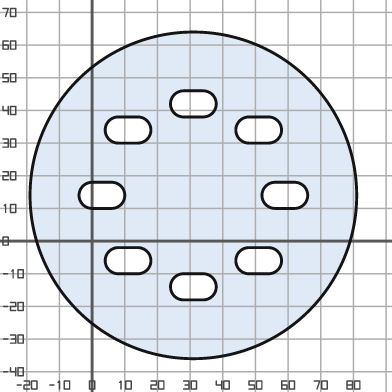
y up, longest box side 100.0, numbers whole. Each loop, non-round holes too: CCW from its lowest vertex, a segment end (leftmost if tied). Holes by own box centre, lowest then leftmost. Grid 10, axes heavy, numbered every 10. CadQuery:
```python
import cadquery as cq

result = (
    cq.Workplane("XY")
    .moveTo(31.0, 14.0)
    .circle(50.0)
    .moveTo(28.0, -18.0)
    .lineTo(34.0, -18.0)
    .threePointArc((38.0, -14.0), (34.0, -10.0))
    .lineTo(28.0, -10.0)
    .threePointArc((24.0, -14.0), (28.0, -18.0))
    .close()
    .moveTo(8.0, -10.0)
    .lineTo(14.0, -10.0)
    .threePointArc((18.0, -6.0), (14.0, -2.0))
    .lineTo(8.0, -2.0)
    .threePointArc((4.0, -6.0), (8.0, -10.0))
    .close()
    .moveTo(48.0, -10.0)
    .lineTo(54.0, -10.0)
    .threePointArc((58.0, -6.0), (54.0, -2.0))
    .lineTo(48.0, -2.0)
    .threePointArc((44.0, -6.0), (48.0, -10.0))
    .close()
    .moveTo(0.0, 10.0)
    .lineTo(6.0, 10.0)
    .threePointArc((10.0, 14.0), (6.0, 18.0))
    .lineTo(0.0, 18.0)
    .threePointArc((-4.0, 14.0), (0.0, 10.0))
    .close()
    .moveTo(56.0, 10.0)
    .lineTo(62.0, 10.0)
    .threePointArc((66.0, 14.0), (62.0, 18.0))
    .lineTo(56.0, 18.0)
    .threePointArc((52.0, 14.0), (56.0, 10.0))
    .close()
    .moveTo(8.0, 30.0)
    .lineTo(14.0, 30.0)
    .threePointArc((18.0, 34.0), (14.0, 38.0))
    .lineTo(8.0, 38.0)
    .threePointArc((4.0, 34.0), (8.0, 30.0))
    .close()
    .moveTo(48.0, 30.0)
    .lineTo(54.0, 30.0)
    .threePointArc((58.0, 34.0), (54.0, 38.0))
    .lineTo(48.0, 38.0)
    .threePointArc((44.0, 34.0), (48.0, 30.0))
    .close()
    .moveTo(28.0, 38.0)
    .lineTo(34.0, 38.0)
    .threePointArc((38.0, 42.0), (34.0, 46.0))
    .lineTo(28.0, 46.0)
    .threePointArc((24.0, 42.0), (28.0, 38.0))
    .close()
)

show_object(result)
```